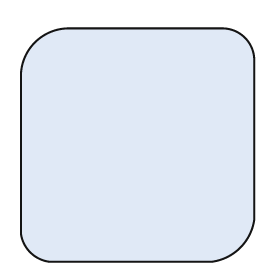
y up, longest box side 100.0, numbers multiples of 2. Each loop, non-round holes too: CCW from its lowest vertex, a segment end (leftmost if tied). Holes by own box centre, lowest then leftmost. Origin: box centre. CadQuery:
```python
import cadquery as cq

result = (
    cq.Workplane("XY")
    .moveTo(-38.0, -50.0)
    .lineTo(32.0, -50.0)
    .threePointArc((44.0, -44.0), (50.0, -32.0))
    .lineTo(50.0, 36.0)
    .threePointArc((46.0, 46.0), (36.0, 50.0))
    .lineTo(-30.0, 50.0)
    .threePointArc((-44.0, 44.0), (-50.0, 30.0))
    .lineTo(-50.0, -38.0)
    .threePointArc((-46.0, -46.0), (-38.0, -50.0))
    .close()
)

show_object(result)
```